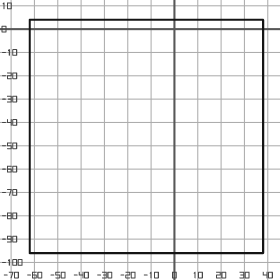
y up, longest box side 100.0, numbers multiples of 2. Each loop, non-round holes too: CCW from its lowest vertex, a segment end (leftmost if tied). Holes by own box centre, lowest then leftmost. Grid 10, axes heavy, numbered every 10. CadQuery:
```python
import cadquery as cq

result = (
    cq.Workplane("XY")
    .moveTo(-62.0, -96.0)
    .lineTo(38.0, -96.0)
    .lineTo(38.0, 4.0)
    .lineTo(-62.0, 4.0)
    .close()
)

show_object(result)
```